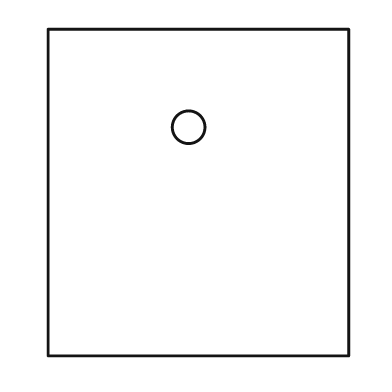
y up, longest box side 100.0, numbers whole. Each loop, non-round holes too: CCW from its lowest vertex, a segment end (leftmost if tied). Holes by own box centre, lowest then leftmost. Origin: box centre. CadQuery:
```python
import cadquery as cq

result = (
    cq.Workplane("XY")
    .moveTo(-46.0, -50.0)
    .lineTo(46.0, -50.0)
    .lineTo(46.0, 50.0)
    .lineTo(-46.0, 50.0)
    .close()
    .moveTo(-3.0, 20.0)
    .circle(5.0)
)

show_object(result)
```